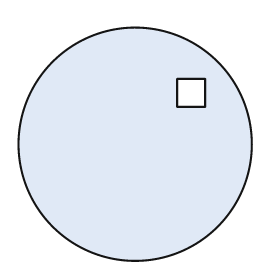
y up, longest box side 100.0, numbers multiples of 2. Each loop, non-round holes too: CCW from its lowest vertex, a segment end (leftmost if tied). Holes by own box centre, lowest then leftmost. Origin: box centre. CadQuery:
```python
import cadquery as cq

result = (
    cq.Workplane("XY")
    .moveTo(0.0, 0.0)
    .circle(50.0)
    .moveTo(18.0, 16.0)
    .lineTo(30.0, 16.0)
    .lineTo(30.0, 28.0)
    .lineTo(18.0, 28.0)
    .close()
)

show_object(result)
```